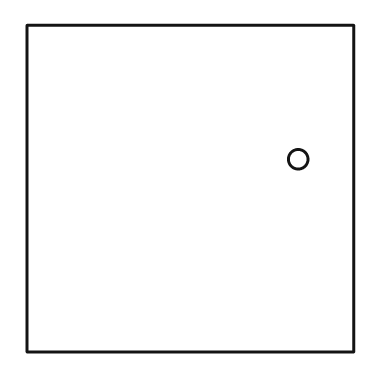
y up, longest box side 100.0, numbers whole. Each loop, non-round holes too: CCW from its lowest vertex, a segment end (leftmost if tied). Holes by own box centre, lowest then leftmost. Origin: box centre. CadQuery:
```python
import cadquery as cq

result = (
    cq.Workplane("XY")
    .moveTo(-50.0, -50.0)
    .lineTo(50.0, -50.0)
    .lineTo(50.0, 50.0)
    .lineTo(-50.0, 50.0)
    .close()
    .moveTo(33.0, 9.0)
    .circle(3.0)
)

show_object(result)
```